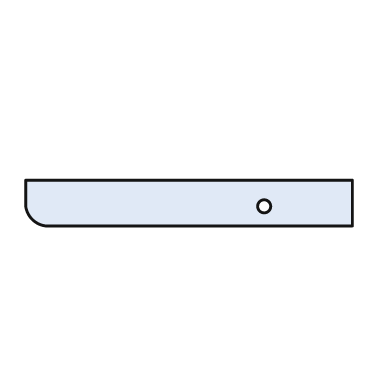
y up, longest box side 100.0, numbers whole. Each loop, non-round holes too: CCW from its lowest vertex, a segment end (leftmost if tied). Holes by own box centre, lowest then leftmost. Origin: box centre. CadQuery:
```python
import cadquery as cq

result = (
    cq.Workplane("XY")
    .moveTo(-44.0, -7.0)
    .lineTo(50.0, -7.0)
    .lineTo(50.0, 7.0)
    .lineTo(-50.0, 7.0)
    .lineTo(-50.0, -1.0)
    .threePointArc((-48.0, -5.0), (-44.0, -7.0))
    .close()
    .moveTo(23.0, -1.0)
    .circle(2.0)
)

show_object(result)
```